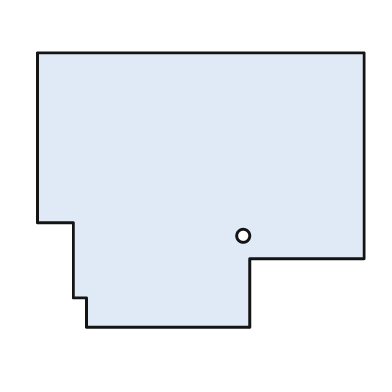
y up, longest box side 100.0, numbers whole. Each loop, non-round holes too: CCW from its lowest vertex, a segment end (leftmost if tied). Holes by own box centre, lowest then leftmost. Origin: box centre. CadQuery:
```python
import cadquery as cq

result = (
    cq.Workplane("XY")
    .moveTo(-35.0, -42.0)
    .lineTo(15.0, -42.0)
    .lineTo(15.0, -21.0)
    .lineTo(50.0, -21.0)
    .lineTo(50.0, 42.0)
    .lineTo(-50.0, 42.0)
    .lineTo(-50.0, -10.0)
    .lineTo(-39.0, -10.0)
    .lineTo(-39.0, -33.0)
    .lineTo(-35.0, -33.0)
    .close()
    .moveTo(13.0, -14.0)
    .circle(2.0)
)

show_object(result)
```